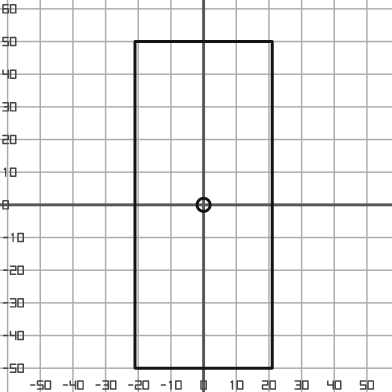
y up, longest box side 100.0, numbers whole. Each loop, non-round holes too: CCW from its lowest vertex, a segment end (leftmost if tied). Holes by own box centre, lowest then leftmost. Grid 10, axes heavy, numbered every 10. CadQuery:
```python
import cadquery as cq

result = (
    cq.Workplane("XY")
    .moveTo(-21.0, -50.0)
    .lineTo(21.0, -50.0)
    .lineTo(21.0, 50.0)
    .lineTo(-21.0, 50.0)
    .close()
    .moveTo(0.0, 0.0)
    .circle(2.0)
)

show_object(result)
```